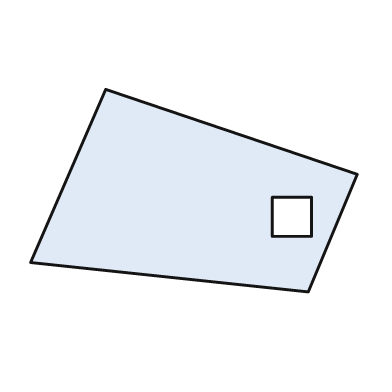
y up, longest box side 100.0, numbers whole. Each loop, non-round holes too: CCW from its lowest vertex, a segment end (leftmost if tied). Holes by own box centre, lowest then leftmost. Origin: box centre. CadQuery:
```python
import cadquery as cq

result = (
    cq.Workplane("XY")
    .moveTo(35.0, -31.0)
    .lineTo(50.0, 5.0)
    .lineTo(-27.0, 31.0)
    .lineTo(-50.0, -22.0)
    .close()
    .moveTo(24.0, -14.0)
    .lineTo(36.0, -14.0)
    .lineTo(36.0, -2.0)
    .lineTo(24.0, -2.0)
    .close()
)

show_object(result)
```